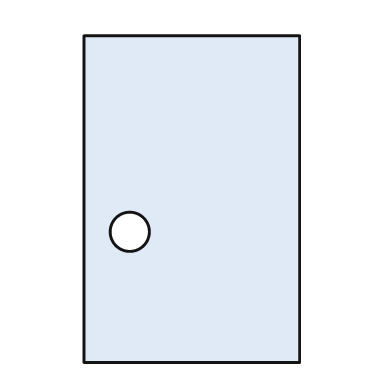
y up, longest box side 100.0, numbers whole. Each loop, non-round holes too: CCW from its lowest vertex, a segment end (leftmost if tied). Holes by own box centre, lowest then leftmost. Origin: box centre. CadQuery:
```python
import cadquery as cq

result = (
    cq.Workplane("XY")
    .moveTo(-33.0, -50.0)
    .lineTo(33.0, -50.0)
    .lineTo(33.0, 50.0)
    .lineTo(-33.0, 50.0)
    .close()
    .moveTo(-19.0, -10.0)
    .circle(6.0)
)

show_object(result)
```